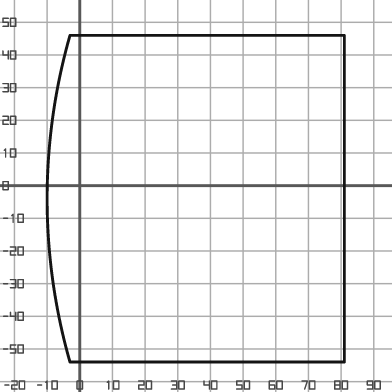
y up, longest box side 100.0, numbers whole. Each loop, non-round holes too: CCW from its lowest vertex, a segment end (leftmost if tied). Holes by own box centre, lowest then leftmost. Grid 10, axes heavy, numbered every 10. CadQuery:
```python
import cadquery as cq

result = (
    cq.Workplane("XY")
    .moveTo(-3.0, -54.0)
    .lineTo(81.0, -54.0)
    .lineTo(81.0, 46.0)
    .lineTo(-3.0, 46.0)
    .threePointArc((-10.0, -4.0), (-3.0, -54.0))
    .close()
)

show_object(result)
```